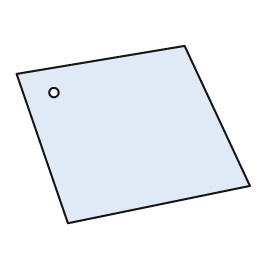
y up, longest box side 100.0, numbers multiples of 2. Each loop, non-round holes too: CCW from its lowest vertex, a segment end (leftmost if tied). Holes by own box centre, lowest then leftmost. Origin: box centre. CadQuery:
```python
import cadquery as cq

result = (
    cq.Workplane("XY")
    .moveTo(-28.0, -38.0)
    .lineTo(50.0, -22.0)
    .lineTo(22.0, 38.0)
    .lineTo(-50.0, 26.0)
    .close()
    .moveTo(-34.0, 18.0)
    .circle(2.0)
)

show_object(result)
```